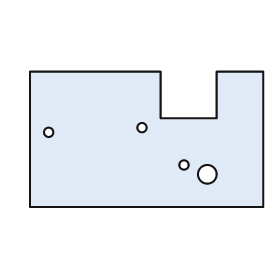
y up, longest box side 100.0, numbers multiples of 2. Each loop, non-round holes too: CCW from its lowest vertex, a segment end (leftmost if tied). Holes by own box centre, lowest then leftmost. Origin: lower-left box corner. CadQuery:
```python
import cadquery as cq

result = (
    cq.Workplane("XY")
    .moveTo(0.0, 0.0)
    .lineTo(100.0, 0.0)
    .lineTo(100.0, 58.0)
    .lineTo(80.0, 58.0)
    .lineTo(80.0, 38.0)
    .lineTo(56.0, 38.0)
    .lineTo(56.0, 58.0)
    .lineTo(0.0, 58.0)
    .close()
    .moveTo(76.0, 14.0)
    .circle(4.0)
    .moveTo(66.0, 18.0)
    .circle(2.0)
    .moveTo(8.0, 32.0)
    .circle(2.0)
    .moveTo(48.0, 34.0)
    .circle(2.0)
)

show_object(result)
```